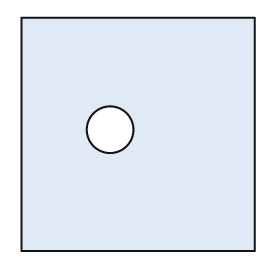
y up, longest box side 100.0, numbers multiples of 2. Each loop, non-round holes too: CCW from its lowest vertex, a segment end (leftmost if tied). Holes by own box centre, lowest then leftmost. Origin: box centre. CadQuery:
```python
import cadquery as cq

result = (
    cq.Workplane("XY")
    .moveTo(-50.0, -50.0)
    .lineTo(50.0, -50.0)
    .lineTo(50.0, 50.0)
    .lineTo(-50.0, 50.0)
    .close()
    .moveTo(-12.0, 2.0)
    .circle(10.0)
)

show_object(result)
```